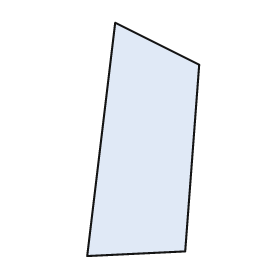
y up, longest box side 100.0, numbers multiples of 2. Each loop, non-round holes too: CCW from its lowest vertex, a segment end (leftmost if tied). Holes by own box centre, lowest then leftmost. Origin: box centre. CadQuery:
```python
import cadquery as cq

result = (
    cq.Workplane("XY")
    .moveTo(-24.0, -50.0)
    .lineTo(18.0, -48.0)
    .lineTo(24.0, 32.0)
    .lineTo(-12.0, 50.0)
    .close()
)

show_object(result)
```